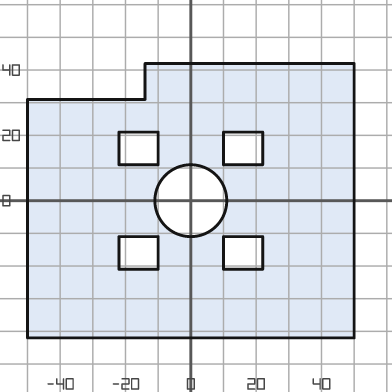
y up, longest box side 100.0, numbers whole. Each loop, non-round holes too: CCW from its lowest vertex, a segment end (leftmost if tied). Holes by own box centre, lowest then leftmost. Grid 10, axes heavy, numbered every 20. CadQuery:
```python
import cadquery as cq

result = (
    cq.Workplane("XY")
    .moveTo(-50.0, -42.0)
    .lineTo(50.0, -42.0)
    .lineTo(50.0, 42.0)
    .lineTo(-14.0, 42.0)
    .lineTo(-14.0, 31.0)
    .lineTo(-50.0, 31.0)
    .close()
    .moveTo(-22.0, -21.0)
    .lineTo(-10.0, -21.0)
    .lineTo(-10.0, -11.0)
    .lineTo(-22.0, -11.0)
    .close()
    .moveTo(10.0, -21.0)
    .lineTo(22.0, -21.0)
    .lineTo(22.0, -11.0)
    .lineTo(10.0, -11.0)
    .close()
    .moveTo(0.0, 0.0)
    .circle(11.0)
    .moveTo(-22.0, 11.0)
    .lineTo(-10.0, 11.0)
    .lineTo(-10.0, 21.0)
    .lineTo(-22.0, 21.0)
    .close()
    .moveTo(10.0, 11.0)
    .lineTo(22.0, 11.0)
    .lineTo(22.0, 21.0)
    .lineTo(10.0, 21.0)
    .close()
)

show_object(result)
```